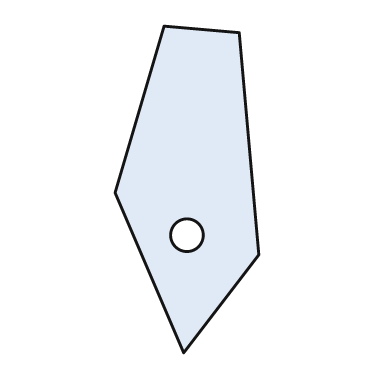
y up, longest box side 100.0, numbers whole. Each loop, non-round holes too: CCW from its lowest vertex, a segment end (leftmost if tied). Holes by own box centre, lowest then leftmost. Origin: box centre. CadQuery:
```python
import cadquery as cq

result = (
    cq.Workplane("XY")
    .moveTo(-1.0, -50.0)
    .lineTo(22.0, -20.0)
    .lineTo(16.0, 48.0)
    .lineTo(-7.0, 50.0)
    .lineTo(-22.0, -1.0)
    .close()
    .moveTo(0.0, -14.0)
    .circle(5.0)
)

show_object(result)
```